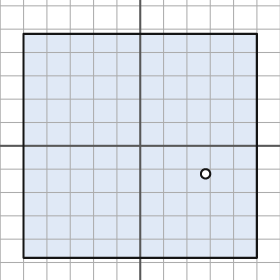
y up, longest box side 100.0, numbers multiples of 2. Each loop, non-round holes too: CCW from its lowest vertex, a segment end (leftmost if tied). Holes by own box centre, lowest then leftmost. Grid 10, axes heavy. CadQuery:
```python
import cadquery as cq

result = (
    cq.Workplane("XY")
    .moveTo(-50.0, -48.0)
    .lineTo(50.0, -48.0)
    .lineTo(50.0, 48.0)
    .lineTo(-50.0, 48.0)
    .close()
    .moveTo(28.0, -12.0)
    .circle(2.0)
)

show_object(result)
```